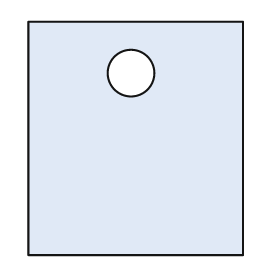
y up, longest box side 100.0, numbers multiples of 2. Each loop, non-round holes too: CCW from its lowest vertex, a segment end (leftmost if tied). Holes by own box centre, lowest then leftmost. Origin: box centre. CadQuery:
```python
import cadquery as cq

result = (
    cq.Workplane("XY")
    .moveTo(-46.0, -50.0)
    .lineTo(46.0, -50.0)
    .lineTo(46.0, 50.0)
    .lineTo(-46.0, 50.0)
    .close()
    .moveTo(-2.0, 28.0)
    .circle(10.0)
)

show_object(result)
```